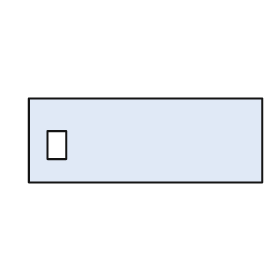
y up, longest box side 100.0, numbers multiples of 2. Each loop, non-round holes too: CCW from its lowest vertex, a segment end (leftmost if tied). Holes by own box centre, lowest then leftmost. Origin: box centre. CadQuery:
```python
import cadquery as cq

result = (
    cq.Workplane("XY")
    .moveTo(-50.0, -18.0)
    .lineTo(50.0, -18.0)
    .lineTo(50.0, 18.0)
    .lineTo(-50.0, 18.0)
    .close()
    .moveTo(-42.0, -8.0)
    .lineTo(-34.0, -8.0)
    .lineTo(-34.0, 4.0)
    .lineTo(-42.0, 4.0)
    .close()
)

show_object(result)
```